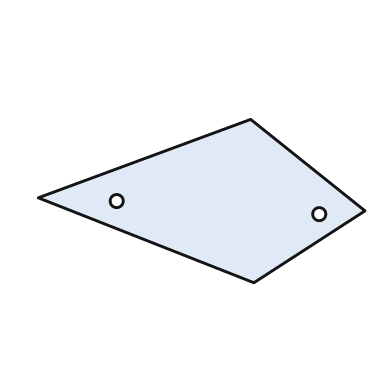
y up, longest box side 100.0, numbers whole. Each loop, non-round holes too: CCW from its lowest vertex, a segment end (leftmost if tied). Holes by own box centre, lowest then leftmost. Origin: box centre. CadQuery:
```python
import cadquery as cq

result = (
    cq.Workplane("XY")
    .moveTo(16.0, -25.0)
    .lineTo(50.0, -3.0)
    .lineTo(15.0, 25.0)
    .lineTo(-50.0, 1.0)
    .close()
    .moveTo(36.0, -4.0)
    .circle(2.0)
    .moveTo(-26.0, 0.0)
    .circle(2.0)
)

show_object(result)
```